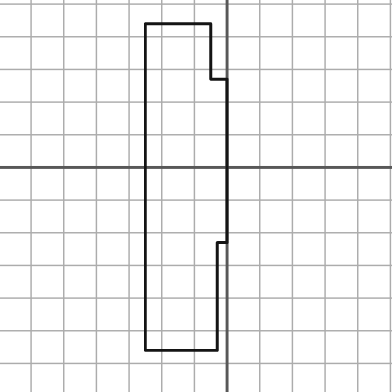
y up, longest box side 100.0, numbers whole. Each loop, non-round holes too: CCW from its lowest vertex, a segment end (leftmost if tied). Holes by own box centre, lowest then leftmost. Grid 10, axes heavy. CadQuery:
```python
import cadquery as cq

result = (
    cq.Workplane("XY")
    .moveTo(-25.0, -56.0)
    .lineTo(-3.0, -56.0)
    .lineTo(-3.0, -23.0)
    .lineTo(0.0, -23.0)
    .lineTo(0.0, 27.0)
    .lineTo(-5.0, 27.0)
    .lineTo(-5.0, 44.0)
    .lineTo(-25.0, 44.0)
    .close()
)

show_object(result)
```